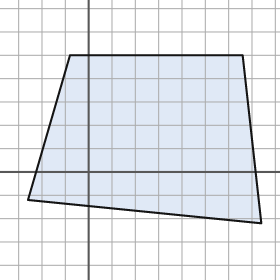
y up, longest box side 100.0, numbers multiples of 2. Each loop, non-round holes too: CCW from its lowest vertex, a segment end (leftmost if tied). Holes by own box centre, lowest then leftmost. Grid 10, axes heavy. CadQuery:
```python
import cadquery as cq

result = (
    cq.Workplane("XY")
    .moveTo(74.0, -22.0)
    .lineTo(66.0, 50.0)
    .lineTo(-8.0, 50.0)
    .lineTo(-26.0, -12.0)
    .close()
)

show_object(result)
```